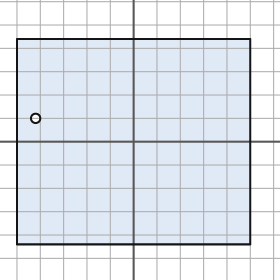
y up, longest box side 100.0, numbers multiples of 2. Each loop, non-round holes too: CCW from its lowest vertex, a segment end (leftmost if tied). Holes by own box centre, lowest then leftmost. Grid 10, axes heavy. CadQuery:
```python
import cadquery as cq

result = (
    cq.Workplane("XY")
    .moveTo(-50.0, -44.0)
    .lineTo(50.0, -44.0)
    .lineTo(50.0, 44.0)
    .lineTo(-50.0, 44.0)
    .close()
    .moveTo(-42.0, 10.0)
    .circle(2.0)
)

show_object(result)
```